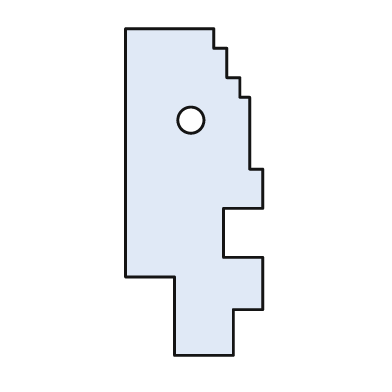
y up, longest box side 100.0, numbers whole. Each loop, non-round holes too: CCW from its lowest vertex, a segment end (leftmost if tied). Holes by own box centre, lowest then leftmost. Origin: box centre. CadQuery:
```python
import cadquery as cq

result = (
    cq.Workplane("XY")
    .moveTo(-6.0, -50.0)
    .lineTo(12.0, -50.0)
    .lineTo(12.0, -36.0)
    .lineTo(21.0, -36.0)
    .lineTo(21.0, -20.0)
    .lineTo(9.0, -20.0)
    .lineTo(9.0, -5.0)
    .lineTo(21.0, -5.0)
    .lineTo(21.0, 7.0)
    .lineTo(17.0, 7.0)
    .lineTo(17.0, 29.0)
    .lineTo(14.0, 29.0)
    .lineTo(14.0, 35.0)
    .lineTo(10.0, 35.0)
    .lineTo(10.0, 44.0)
    .lineTo(6.0, 44.0)
    .lineTo(6.0, 50.0)
    .lineTo(-21.0, 50.0)
    .lineTo(-21.0, -26.0)
    .lineTo(-6.0, -26.0)
    .close()
    .moveTo(-1.0, 22.0)
    .circle(4.0)
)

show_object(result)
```